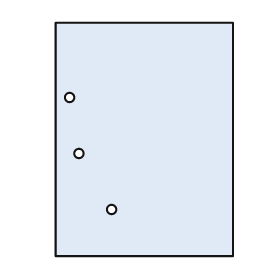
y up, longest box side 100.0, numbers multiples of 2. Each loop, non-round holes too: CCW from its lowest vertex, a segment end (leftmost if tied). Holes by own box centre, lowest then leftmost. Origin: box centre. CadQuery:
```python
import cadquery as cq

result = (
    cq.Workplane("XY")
    .moveTo(-38.0, -50.0)
    .lineTo(38.0, -50.0)
    .lineTo(38.0, 50.0)
    .lineTo(-38.0, 50.0)
    .close()
    .moveTo(-14.0, -30.0)
    .circle(2.0)
    .moveTo(-28.0, -6.0)
    .circle(2.0)
    .moveTo(-32.0, 18.0)
    .circle(2.0)
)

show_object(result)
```